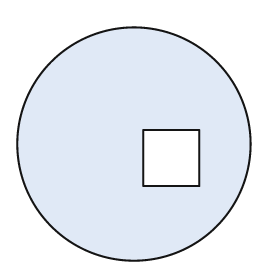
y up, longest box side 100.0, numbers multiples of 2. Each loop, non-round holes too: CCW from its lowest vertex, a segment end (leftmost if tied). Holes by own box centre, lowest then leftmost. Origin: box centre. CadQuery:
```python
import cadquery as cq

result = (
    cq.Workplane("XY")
    .moveTo(0.0, 0.0)
    .circle(50.0)
    .moveTo(4.0, -18.0)
    .lineTo(28.0, -18.0)
    .lineTo(28.0, 6.0)
    .lineTo(4.0, 6.0)
    .close()
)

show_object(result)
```